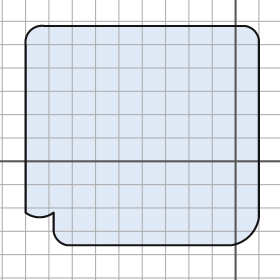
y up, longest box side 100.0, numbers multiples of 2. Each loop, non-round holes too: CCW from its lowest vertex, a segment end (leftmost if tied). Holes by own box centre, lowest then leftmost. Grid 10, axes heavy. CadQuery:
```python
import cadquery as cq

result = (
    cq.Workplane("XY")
    .moveTo(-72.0, -36.0)
    .lineTo(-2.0, -36.0)
    .threePointArc((6.0, -32.0), (10.0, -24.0))
    .lineTo(10.0, 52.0)
    .threePointArc((8.0, 56.0), (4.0, 58.0))
    .lineTo(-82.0, 58.0)
    .threePointArc((-88.0, 56.0), (-90.0, 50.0))
    .lineTo(-90.0, -22.0)
    .threePointArc((-84.0, -24.0), (-78.0, -22.0))
    .lineTo(-78.0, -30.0)
    .threePointArc((-76.0, -34.0), (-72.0, -36.0))
    .close()
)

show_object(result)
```